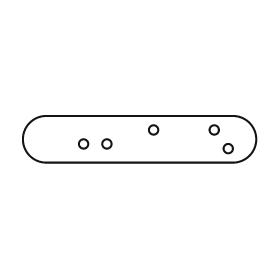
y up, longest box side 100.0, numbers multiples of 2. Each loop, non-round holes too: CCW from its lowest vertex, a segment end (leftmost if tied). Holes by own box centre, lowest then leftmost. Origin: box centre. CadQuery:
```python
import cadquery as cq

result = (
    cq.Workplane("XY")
    .moveTo(-40.0, -10.0)
    .lineTo(40.0, -10.0)
    .threePointArc((50.0, 0.0), (40.0, 10.0))
    .lineTo(-40.0, 10.0)
    .threePointArc((-50.0, 0.0), (-40.0, -10.0))
    .close()
    .moveTo(38.0, -4.0)
    .circle(2.0)
    .moveTo(-24.0, -2.0)
    .circle(2.0)
    .moveTo(-14.0, -2.0)
    .circle(2.0)
    .moveTo(6.0, 4.0)
    .circle(2.0)
    .moveTo(32.0, 4.0)
    .circle(2.0)
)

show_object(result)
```